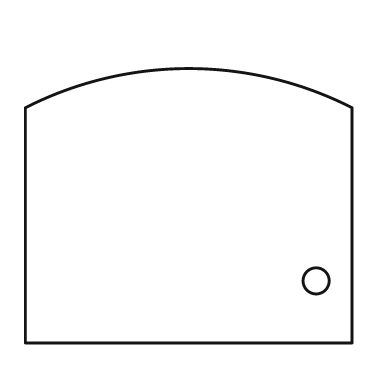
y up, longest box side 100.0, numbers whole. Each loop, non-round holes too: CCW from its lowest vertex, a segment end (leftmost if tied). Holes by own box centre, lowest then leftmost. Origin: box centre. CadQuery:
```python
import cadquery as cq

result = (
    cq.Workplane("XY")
    .moveTo(-50.0, -42.0)
    .lineTo(50.0, -42.0)
    .lineTo(50.0, 30.0)
    .threePointArc((0.0, 42.0), (-50.0, 30.0))
    .close()
    .moveTo(39.0, -23.0)
    .circle(4.0)
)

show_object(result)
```